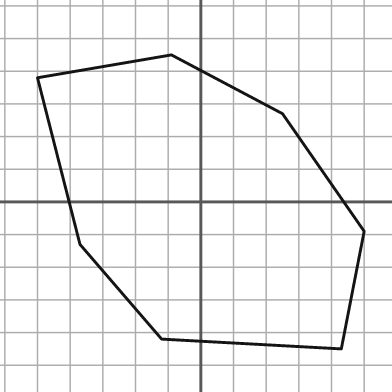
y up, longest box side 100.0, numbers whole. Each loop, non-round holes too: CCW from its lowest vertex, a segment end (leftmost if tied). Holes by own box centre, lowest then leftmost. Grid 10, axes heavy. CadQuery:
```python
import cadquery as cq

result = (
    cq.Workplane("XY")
    .moveTo(43.0, -45.0)
    .lineTo(50.0, -9.0)
    .lineTo(25.0, 27.0)
    .lineTo(-9.0, 45.0)
    .lineTo(-50.0, 38.0)
    .lineTo(-37.0, -13.0)
    .lineTo(-12.0, -42.0)
    .close()
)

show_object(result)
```